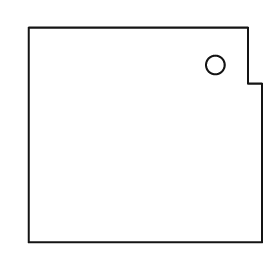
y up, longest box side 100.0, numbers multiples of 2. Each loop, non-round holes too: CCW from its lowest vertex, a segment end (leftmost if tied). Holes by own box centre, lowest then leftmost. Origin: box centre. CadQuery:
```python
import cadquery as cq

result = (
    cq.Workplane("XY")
    .moveTo(-50.0, -46.0)
    .lineTo(50.0, -46.0)
    .lineTo(50.0, 22.0)
    .lineTo(44.0, 22.0)
    .lineTo(44.0, 46.0)
    .lineTo(-50.0, 46.0)
    .close()
    .moveTo(30.0, 30.0)
    .circle(4.0)
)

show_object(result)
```